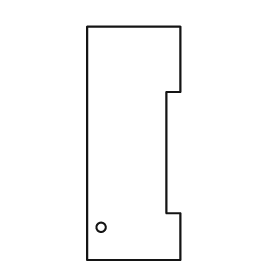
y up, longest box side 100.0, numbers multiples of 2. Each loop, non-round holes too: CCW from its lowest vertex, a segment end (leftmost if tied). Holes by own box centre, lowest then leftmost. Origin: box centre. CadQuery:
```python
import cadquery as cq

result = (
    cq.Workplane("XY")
    .moveTo(-20.0, -50.0)
    .lineTo(20.0, -50.0)
    .lineTo(20.0, -30.0)
    .lineTo(14.0, -30.0)
    .lineTo(14.0, 22.0)
    .lineTo(20.0, 22.0)
    .lineTo(20.0, 50.0)
    .lineTo(-20.0, 50.0)
    .close()
    .moveTo(-14.0, -36.0)
    .circle(2.0)
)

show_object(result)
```